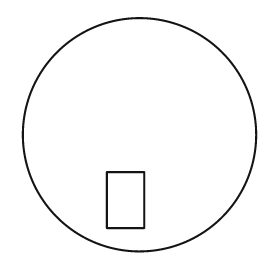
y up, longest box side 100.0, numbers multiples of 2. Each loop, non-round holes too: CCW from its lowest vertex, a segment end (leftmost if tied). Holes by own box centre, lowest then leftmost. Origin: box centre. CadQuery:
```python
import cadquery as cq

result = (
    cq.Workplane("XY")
    .moveTo(0.0, 0.0)
    .circle(50.0)
    .moveTo(-14.0, -40.0)
    .lineTo(2.0, -40.0)
    .lineTo(2.0, -16.0)
    .lineTo(-14.0, -16.0)
    .close()
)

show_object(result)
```